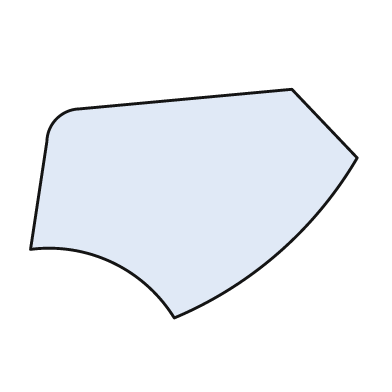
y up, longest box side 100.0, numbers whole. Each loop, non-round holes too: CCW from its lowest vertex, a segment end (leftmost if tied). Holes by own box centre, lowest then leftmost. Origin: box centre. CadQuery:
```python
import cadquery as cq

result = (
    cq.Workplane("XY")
    .moveTo(-6.0, -35.0)
    .threePointArc((26.0, -15.0), (50.0, 14.0))
    .lineTo(30.0, 35.0)
    .lineTo(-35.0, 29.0)
    .threePointArc((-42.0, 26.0), (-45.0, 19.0))
    .lineTo(-50.0, -14.0)
    .threePointArc((-25.0, -18.0), (-6.0, -35.0))
    .close()
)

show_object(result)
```